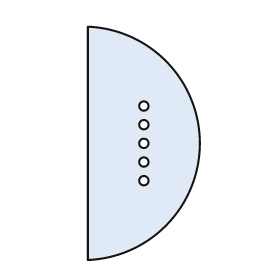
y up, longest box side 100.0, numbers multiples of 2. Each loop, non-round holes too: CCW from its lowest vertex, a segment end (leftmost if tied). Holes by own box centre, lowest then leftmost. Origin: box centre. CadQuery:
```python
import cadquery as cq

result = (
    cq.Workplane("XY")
    .moveTo(-24.0, -50.0)
    .threePointArc((24.0, 0.0), (-24.0, 50.0))
    .close()
    .moveTo(0.0, -16.0)
    .circle(2.0)
    .moveTo(0.0, -8.0)
    .circle(2.0)
    .moveTo(0.0, 0.0)
    .circle(2.0)
    .moveTo(0.0, 8.0)
    .circle(2.0)
    .moveTo(0.0, 16.0)
    .circle(2.0)
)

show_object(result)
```